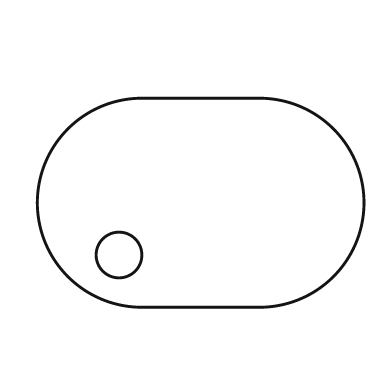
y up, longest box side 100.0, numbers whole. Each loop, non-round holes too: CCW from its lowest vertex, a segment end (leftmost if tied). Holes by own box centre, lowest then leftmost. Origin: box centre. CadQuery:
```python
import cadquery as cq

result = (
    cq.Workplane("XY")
    .moveTo(-18.0, -32.0)
    .lineTo(18.0, -32.0)
    .threePointArc((50.0, 0.0), (18.0, 32.0))
    .lineTo(-18.0, 32.0)
    .threePointArc((-50.0, 0.0), (-18.0, -32.0))
    .close()
    .moveTo(-25.0, -16.0)
    .circle(7.0)
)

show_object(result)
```